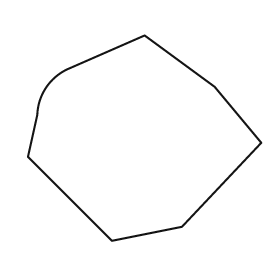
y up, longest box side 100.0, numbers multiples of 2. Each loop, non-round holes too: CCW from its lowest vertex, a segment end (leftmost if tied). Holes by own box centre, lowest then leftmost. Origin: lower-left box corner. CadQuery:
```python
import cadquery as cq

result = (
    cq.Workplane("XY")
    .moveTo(36.0, 0.0)
    .lineTo(66.0, 6.0)
    .lineTo(100.0, 42.0)
    .lineTo(80.0, 66.0)
    .lineTo(50.0, 88.0)
    .lineTo(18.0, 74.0)
    .threePointArc((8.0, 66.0), (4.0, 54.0))
    .lineTo(0.0, 36.0)
    .close()
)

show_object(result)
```